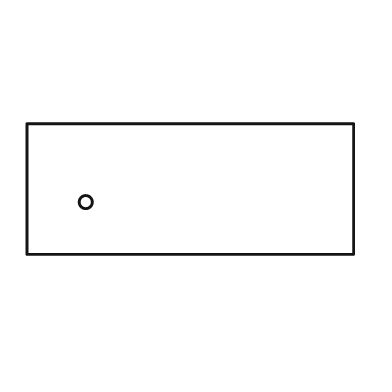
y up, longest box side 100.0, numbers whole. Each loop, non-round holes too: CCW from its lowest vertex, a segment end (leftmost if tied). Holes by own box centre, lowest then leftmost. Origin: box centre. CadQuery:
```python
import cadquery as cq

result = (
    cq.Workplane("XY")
    .moveTo(-50.0, -20.0)
    .lineTo(50.0, -20.0)
    .lineTo(50.0, 20.0)
    .lineTo(-50.0, 20.0)
    .close()
    .moveTo(-32.0, -4.0)
    .circle(2.0)
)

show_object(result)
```